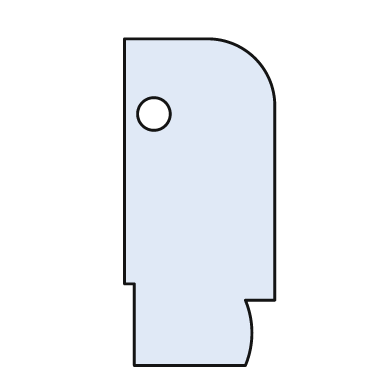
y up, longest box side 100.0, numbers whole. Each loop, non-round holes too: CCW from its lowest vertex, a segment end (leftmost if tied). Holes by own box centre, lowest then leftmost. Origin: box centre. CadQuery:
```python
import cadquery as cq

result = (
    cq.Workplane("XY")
    .moveTo(-20.0, -50.0)
    .lineTo(14.0, -50.0)
    .threePointArc((16.0, -40.0), (14.0, -30.0))
    .lineTo(23.0, -30.0)
    .lineTo(23.0, 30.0)
    .threePointArc((17.0, 44.0), (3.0, 50.0))
    .lineTo(-23.0, 50.0)
    .lineTo(-23.0, -25.0)
    .lineTo(-20.0, -25.0)
    .close()
    .moveTo(-14.0, 27.0)
    .circle(5.0)
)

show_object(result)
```